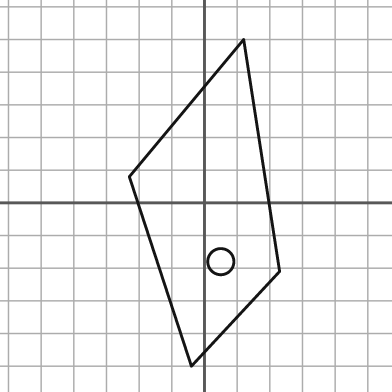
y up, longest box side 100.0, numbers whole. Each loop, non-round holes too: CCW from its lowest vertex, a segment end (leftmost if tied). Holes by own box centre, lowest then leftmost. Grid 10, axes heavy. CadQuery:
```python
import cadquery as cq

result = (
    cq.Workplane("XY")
    .moveTo(-4.0, -50.0)
    .lineTo(23.0, -21.0)
    .lineTo(12.0, 50.0)
    .lineTo(-23.0, 8.0)
    .close()
    .moveTo(5.0, -18.0)
    .circle(4.0)
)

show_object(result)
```